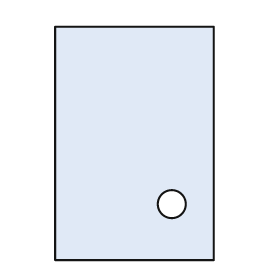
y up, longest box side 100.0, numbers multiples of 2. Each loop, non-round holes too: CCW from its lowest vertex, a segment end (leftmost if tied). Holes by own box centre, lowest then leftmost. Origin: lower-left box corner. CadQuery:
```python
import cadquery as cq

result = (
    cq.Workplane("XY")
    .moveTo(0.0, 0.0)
    .lineTo(68.0, 0.0)
    .lineTo(68.0, 100.0)
    .lineTo(0.0, 100.0)
    .close()
    .moveTo(50.0, 24.0)
    .circle(6.0)
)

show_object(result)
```